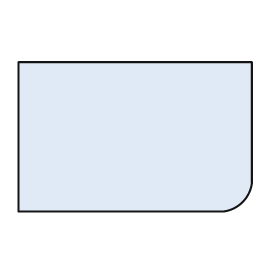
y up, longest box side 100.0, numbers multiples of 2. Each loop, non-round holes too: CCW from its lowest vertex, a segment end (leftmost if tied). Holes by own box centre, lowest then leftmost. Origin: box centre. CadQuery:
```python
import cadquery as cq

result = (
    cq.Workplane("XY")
    .moveTo(-50.0, -32.0)
    .lineTo(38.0, -32.0)
    .threePointArc((46.0, -28.0), (50.0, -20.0))
    .lineTo(50.0, 32.0)
    .lineTo(-50.0, 32.0)
    .close()
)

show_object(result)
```